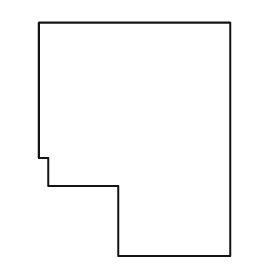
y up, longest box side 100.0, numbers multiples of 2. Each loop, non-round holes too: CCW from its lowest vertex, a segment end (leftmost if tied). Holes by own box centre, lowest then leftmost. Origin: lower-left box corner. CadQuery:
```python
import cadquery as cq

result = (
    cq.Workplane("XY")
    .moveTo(34.0, 0.0)
    .lineTo(82.0, 0.0)
    .lineTo(82.0, 100.0)
    .lineTo(0.0, 100.0)
    .lineTo(0.0, 42.0)
    .lineTo(4.0, 42.0)
    .lineTo(4.0, 30.0)
    .lineTo(34.0, 30.0)
    .close()
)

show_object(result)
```